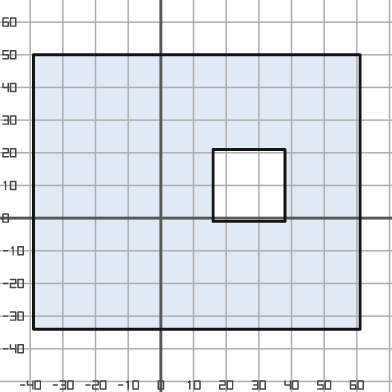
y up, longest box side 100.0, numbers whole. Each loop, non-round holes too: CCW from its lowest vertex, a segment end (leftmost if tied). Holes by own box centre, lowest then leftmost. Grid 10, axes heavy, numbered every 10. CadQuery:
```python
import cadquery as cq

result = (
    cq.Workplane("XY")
    .moveTo(-39.0, -34.0)
    .lineTo(61.0, -34.0)
    .lineTo(61.0, 50.0)
    .lineTo(-39.0, 50.0)
    .close()
    .moveTo(16.0, -1.0)
    .lineTo(38.0, -1.0)
    .lineTo(38.0, 21.0)
    .lineTo(16.0, 21.0)
    .close()
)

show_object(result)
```